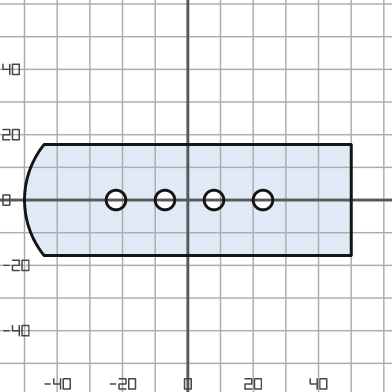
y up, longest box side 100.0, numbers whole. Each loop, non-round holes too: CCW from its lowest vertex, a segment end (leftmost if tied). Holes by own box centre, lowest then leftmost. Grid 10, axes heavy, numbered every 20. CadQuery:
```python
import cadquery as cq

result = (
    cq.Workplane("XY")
    .moveTo(-44.0, -17.0)
    .lineTo(50.0, -17.0)
    .lineTo(50.0, 17.0)
    .lineTo(-44.0, 17.0)
    .threePointArc((-50.0, 0.0), (-44.0, -17.0))
    .close()
    .moveTo(-22.0, 0.0)
    .circle(3.0)
    .moveTo(-7.0, 0.0)
    .circle(3.0)
    .moveTo(8.0, 0.0)
    .circle(3.0)
    .moveTo(23.0, 0.0)
    .circle(3.0)
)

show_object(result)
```